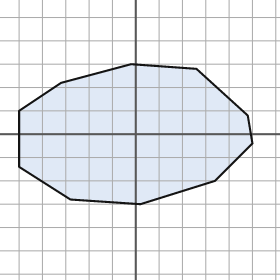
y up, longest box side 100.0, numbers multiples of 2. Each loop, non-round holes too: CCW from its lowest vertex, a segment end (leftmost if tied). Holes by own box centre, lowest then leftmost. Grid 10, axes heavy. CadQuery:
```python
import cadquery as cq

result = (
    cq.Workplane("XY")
    .moveTo(2.0, -30.0)
    .lineTo(34.0, -20.0)
    .lineTo(50.0, -4.0)
    .lineTo(48.0, 8.0)
    .lineTo(26.0, 28.0)
    .lineTo(-2.0, 30.0)
    .lineTo(-32.0, 22.0)
    .lineTo(-50.0, 10.0)
    .lineTo(-50.0, -14.0)
    .lineTo(-28.0, -28.0)
    .close()
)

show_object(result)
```